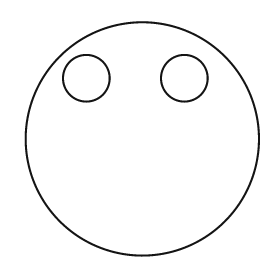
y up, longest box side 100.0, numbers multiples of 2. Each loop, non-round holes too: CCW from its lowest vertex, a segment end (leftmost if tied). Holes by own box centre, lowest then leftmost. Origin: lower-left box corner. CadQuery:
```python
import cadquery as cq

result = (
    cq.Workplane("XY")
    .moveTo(50.0, 50.0)
    .circle(50.0)
    .moveTo(26.0, 76.0)
    .circle(10.0)
    .moveTo(68.0, 76.0)
    .circle(10.0)
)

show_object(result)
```